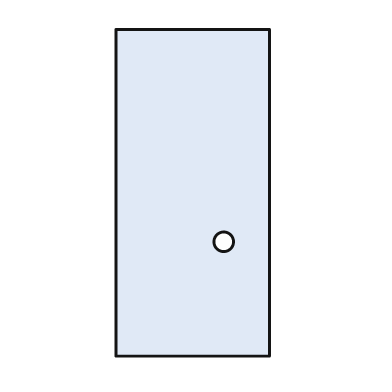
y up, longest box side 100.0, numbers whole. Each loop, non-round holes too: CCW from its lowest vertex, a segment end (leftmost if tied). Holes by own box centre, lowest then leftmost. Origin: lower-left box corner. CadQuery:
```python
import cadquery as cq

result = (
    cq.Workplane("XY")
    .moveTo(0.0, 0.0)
    .lineTo(47.0, 0.0)
    .lineTo(47.0, 100.0)
    .lineTo(0.0, 100.0)
    .close()
    .moveTo(33.0, 35.0)
    .circle(3.0)
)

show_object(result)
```